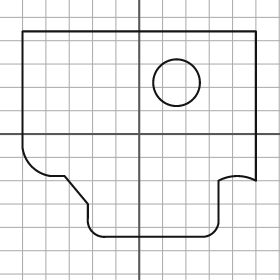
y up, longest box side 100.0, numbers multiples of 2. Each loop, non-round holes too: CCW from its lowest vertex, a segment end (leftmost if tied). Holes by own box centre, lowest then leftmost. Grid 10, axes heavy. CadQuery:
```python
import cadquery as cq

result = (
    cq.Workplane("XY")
    .moveTo(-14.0, -44.0)
    .lineTo(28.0, -44.0)
    .threePointArc((32.0, -42.0), (34.0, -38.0))
    .lineTo(34.0, -20.0)
    .threePointArc((42.0, -18.0), (50.0, -20.0))
    .lineTo(50.0, 44.0)
    .lineTo(-50.0, 44.0)
    .lineTo(-50.0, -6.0)
    .threePointArc((-46.0, -14.0), (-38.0, -18.0))
    .lineTo(-32.0, -18.0)
    .lineTo(-22.0, -30.0)
    .lineTo(-22.0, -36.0)
    .threePointArc((-20.0, -42.0), (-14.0, -44.0))
    .close()
    .moveTo(16.0, 22.0)
    .circle(10.0)
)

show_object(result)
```